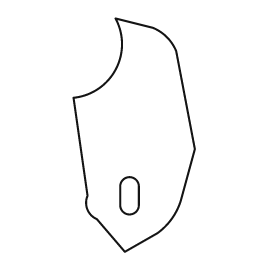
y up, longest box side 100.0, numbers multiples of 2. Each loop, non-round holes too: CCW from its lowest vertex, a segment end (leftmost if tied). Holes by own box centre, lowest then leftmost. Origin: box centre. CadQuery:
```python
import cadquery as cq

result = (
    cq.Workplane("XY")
    .moveTo(-4.0, -50.0)
    .lineTo(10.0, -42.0)
    .threePointArc((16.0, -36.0), (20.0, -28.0))
    .lineTo(26.0, -6.0)
    .lineTo(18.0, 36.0)
    .threePointArc((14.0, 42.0), (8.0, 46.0))
    .lineTo(-8.0, 50.0)
    .threePointArc((-8.0, 28.0), (-26.0, 16.0))
    .lineTo(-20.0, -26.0)
    .threePointArc((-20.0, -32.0), (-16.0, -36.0))
    .close()
    .moveTo(-6.0, -30.0)
    .threePointArc((-2.0, -34.0), (2.0, -30.0))
    .lineTo(2.0, -22.0)
    .threePointArc((-2.0, -18.0), (-6.0, -22.0))
    .close()
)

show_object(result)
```